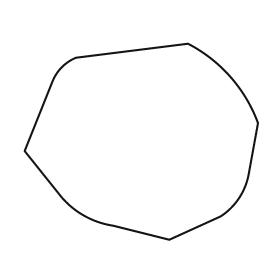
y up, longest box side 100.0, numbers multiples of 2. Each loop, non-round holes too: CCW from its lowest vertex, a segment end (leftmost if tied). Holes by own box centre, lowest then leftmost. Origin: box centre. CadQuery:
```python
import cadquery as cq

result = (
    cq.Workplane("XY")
    .moveTo(12.0, -42.0)
    .lineTo(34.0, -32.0)
    .threePointArc((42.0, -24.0), (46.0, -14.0))
    .lineTo(50.0, 8.0)
    .threePointArc((38.0, 28.0), (20.0, 42.0))
    .lineTo(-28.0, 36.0)
    .threePointArc((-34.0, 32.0), (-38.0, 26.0))
    .lineTo(-50.0, -4.0)
    .lineTo(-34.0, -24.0)
    .threePointArc((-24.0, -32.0), (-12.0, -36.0))
    .close()
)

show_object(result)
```